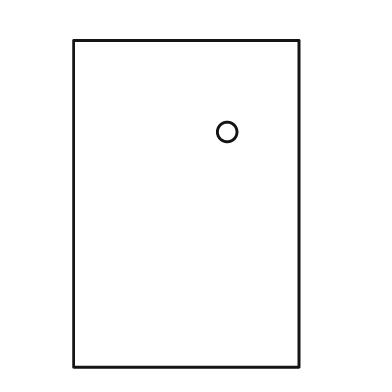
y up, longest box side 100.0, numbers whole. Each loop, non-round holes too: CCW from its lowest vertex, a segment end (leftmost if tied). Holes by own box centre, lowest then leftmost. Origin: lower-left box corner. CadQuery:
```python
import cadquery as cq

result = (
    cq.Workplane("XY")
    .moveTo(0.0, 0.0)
    .lineTo(69.0, 0.0)
    .lineTo(69.0, 100.0)
    .lineTo(0.0, 100.0)
    .close()
    .moveTo(47.0, 72.0)
    .circle(3.0)
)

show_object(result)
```